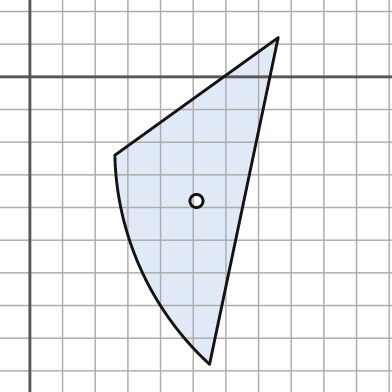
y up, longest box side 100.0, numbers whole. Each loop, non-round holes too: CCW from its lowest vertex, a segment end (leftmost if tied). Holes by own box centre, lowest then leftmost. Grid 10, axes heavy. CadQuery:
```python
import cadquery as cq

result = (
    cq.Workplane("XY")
    .moveTo(55.0, -88.0)
    .lineTo(76.0, 12.0)
    .lineTo(26.0, -24.0)
    .threePointArc((34.0, -59.0), (55.0, -88.0))
    .close()
    .moveTo(51.0, -38.0)
    .circle(2.0)
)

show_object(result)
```